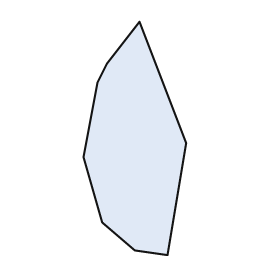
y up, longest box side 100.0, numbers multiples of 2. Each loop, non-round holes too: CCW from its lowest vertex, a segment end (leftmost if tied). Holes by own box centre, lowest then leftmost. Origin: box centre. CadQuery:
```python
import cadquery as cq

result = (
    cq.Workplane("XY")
    .moveTo(14.0, -50.0)
    .lineTo(22.0, -2.0)
    .lineTo(2.0, 50.0)
    .lineTo(-12.0, 32.0)
    .lineTo(-16.0, 24.0)
    .lineTo(-22.0, -8.0)
    .lineTo(-14.0, -36.0)
    .lineTo(0.0, -48.0)
    .close()
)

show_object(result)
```